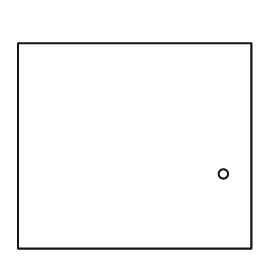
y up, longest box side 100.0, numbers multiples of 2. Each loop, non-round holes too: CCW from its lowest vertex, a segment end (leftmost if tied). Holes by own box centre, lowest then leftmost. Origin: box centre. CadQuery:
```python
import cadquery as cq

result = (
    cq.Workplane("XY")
    .moveTo(-50.0, -44.0)
    .lineTo(50.0, -44.0)
    .lineTo(50.0, 44.0)
    .lineTo(-50.0, 44.0)
    .close()
    .moveTo(38.0, -12.0)
    .circle(2.0)
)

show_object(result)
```